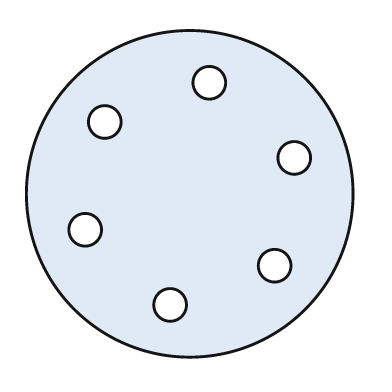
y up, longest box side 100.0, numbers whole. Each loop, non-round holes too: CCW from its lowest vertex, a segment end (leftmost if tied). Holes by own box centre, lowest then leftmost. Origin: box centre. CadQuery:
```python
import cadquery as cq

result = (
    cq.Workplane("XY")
    .moveTo(0.0, 0.0)
    .circle(50.0)
    .moveTo(-6.0, -34.0)
    .circle(5.0)
    .moveTo(26.0, -22.0)
    .circle(5.0)
    .moveTo(-32.0, -11.0)
    .circle(5.0)
    .moveTo(32.0, 11.0)
    .circle(5.0)
    .moveTo(-26.0, 22.0)
    .circle(5.0)
    .moveTo(6.0, 34.0)
    .circle(5.0)
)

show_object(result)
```